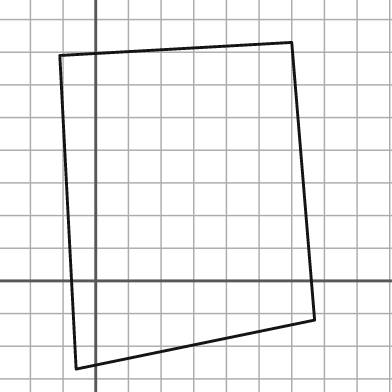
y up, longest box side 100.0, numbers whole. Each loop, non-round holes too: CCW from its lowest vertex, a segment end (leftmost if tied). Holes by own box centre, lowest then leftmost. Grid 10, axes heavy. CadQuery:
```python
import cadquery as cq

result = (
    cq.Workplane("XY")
    .moveTo(-6.0, -27.0)
    .lineTo(67.0, -12.0)
    .lineTo(60.0, 73.0)
    .lineTo(-11.0, 69.0)
    .close()
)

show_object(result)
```